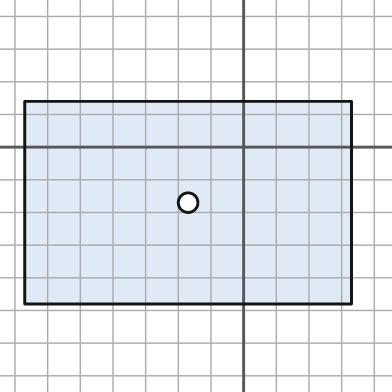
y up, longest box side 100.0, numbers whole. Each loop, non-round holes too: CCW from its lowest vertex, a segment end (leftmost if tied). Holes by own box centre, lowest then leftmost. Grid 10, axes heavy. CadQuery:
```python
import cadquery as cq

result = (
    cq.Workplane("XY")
    .moveTo(-67.0, -48.0)
    .lineTo(33.0, -48.0)
    .lineTo(33.0, 14.0)
    .lineTo(-67.0, 14.0)
    .close()
    .moveTo(-17.0, -17.0)
    .circle(3.0)
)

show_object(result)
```